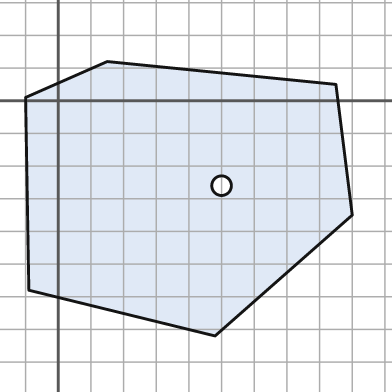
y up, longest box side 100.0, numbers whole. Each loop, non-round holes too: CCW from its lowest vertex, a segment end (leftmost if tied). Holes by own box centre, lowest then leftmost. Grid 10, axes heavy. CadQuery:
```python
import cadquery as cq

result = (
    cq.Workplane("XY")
    .moveTo(48.0, -72.0)
    .lineTo(90.0, -35.0)
    .lineTo(85.0, 5.0)
    .lineTo(15.0, 12.0)
    .lineTo(-10.0, 1.0)
    .lineTo(-9.0, -58.0)
    .close()
    .moveTo(50.0, -26.0)
    .circle(3.0)
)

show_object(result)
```